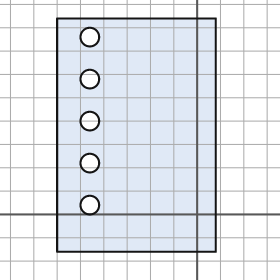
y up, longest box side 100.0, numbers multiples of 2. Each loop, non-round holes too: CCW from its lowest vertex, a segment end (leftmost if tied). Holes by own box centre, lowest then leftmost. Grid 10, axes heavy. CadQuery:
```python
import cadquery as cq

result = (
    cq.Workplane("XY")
    .moveTo(-60.0, -16.0)
    .lineTo(8.0, -16.0)
    .lineTo(8.0, 84.0)
    .lineTo(-60.0, 84.0)
    .close()
    .moveTo(-46.0, 4.0)
    .circle(4.0)
    .moveTo(-46.0, 22.0)
    .circle(4.0)
    .moveTo(-46.0, 40.0)
    .circle(4.0)
    .moveTo(-46.0, 58.0)
    .circle(4.0)
    .moveTo(-46.0, 76.0)
    .circle(4.0)
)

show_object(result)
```